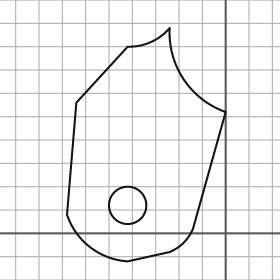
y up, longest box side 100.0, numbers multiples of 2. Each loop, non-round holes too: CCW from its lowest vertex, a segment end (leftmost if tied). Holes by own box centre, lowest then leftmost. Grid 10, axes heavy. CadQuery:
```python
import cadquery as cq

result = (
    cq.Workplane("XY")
    .moveTo(-42.0, -12.0)
    .lineTo(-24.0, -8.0)
    .threePointArc((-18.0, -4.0), (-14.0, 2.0))
    .lineTo(0.0, 52.0)
    .threePointArc((-18.0, 66.0), (-24.0, 88.0))
    .threePointArc((-32.0, 82.0), (-42.0, 80.0))
    .lineTo(-64.0, 56.0)
    .lineTo(-68.0, 8.0)
    .threePointArc((-58.0, -6.0), (-42.0, -12.0))
    .close()
    .moveTo(-42.0, 12.0)
    .circle(8.0)
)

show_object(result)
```